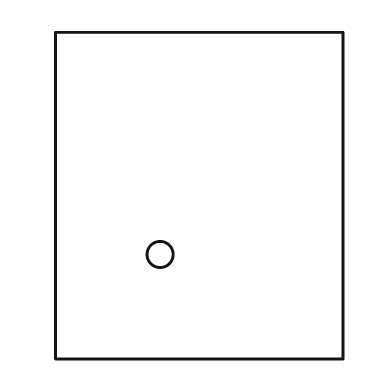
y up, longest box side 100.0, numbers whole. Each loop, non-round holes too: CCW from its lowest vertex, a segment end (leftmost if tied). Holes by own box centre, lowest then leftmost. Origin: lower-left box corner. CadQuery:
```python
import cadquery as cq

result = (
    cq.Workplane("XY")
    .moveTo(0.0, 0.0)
    .lineTo(88.0, 0.0)
    .lineTo(88.0, 100.0)
    .lineTo(0.0, 100.0)
    .close()
    .moveTo(32.0, 32.0)
    .circle(4.0)
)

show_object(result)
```